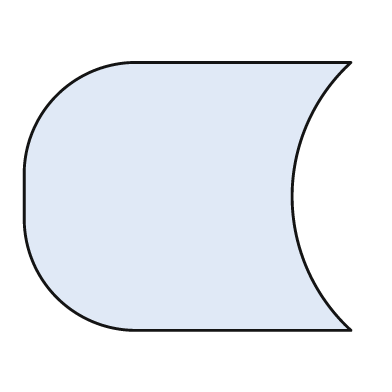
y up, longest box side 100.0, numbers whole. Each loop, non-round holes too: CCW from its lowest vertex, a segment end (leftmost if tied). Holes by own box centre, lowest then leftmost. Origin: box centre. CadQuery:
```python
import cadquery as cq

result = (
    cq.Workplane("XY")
    .moveTo(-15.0, -41.0)
    .lineTo(50.0, -41.0)
    .threePointArc((32.0, 0.0), (50.0, 41.0))
    .lineTo(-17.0, 41.0)
    .threePointArc((-40.0, 31.0), (-50.0, 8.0))
    .lineTo(-50.0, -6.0)
    .threePointArc((-40.0, -31.0), (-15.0, -41.0))
    .close()
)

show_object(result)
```